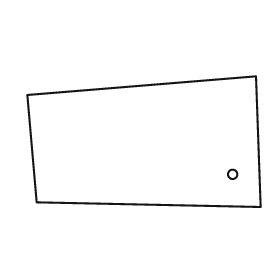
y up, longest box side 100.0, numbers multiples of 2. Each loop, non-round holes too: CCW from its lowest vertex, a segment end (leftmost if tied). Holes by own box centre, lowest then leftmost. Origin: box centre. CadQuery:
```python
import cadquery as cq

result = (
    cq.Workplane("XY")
    .moveTo(50.0, -28.0)
    .lineTo(48.0, 28.0)
    .lineTo(-50.0, 20.0)
    .lineTo(-46.0, -26.0)
    .close()
    .moveTo(38.0, -14.0)
    .circle(2.0)
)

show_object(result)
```